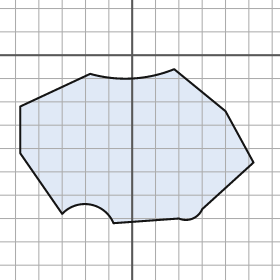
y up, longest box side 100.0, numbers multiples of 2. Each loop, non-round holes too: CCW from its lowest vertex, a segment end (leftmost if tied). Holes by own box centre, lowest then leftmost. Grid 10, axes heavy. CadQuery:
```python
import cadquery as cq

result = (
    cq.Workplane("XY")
    .moveTo(-8.0, -72.0)
    .lineTo(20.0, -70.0)
    .threePointArc((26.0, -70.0), (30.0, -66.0))
    .lineTo(52.0, -46.0)
    .lineTo(40.0, -24.0)
    .lineTo(18.0, -6.0)
    .threePointArc((0.0, -10.0), (-18.0, -8.0))
    .lineTo(-48.0, -22.0)
    .lineTo(-48.0, -42.0)
    .lineTo(-30.0, -68.0)
    .threePointArc((-18.0, -64.0), (-8.0, -72.0))
    .close()
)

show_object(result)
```